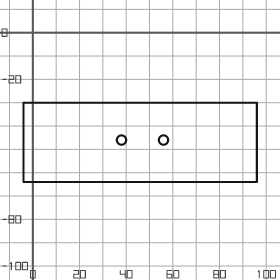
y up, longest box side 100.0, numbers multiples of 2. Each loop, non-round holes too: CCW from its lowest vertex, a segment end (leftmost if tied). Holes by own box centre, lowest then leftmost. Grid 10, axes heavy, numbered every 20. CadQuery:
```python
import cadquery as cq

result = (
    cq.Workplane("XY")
    .moveTo(-4.0, -64.0)
    .lineTo(96.0, -64.0)
    .lineTo(96.0, -30.0)
    .lineTo(-4.0, -30.0)
    .close()
    .moveTo(38.0, -46.0)
    .circle(2.0)
    .moveTo(56.0, -46.0)
    .circle(2.0)
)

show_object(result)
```